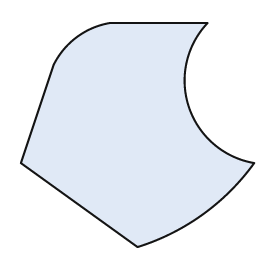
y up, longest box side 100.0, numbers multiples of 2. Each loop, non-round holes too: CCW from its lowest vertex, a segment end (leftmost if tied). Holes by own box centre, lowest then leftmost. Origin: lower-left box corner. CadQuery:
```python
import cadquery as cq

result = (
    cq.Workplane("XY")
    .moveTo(50.0, 0.0)
    .threePointArc((78.0, 14.0), (100.0, 36.0))
    .threePointArc((72.0, 60.0), (80.0, 96.0))
    .lineTo(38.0, 96.0)
    .threePointArc((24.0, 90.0), (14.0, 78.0))
    .lineTo(0.0, 36.0)
    .close()
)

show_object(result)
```